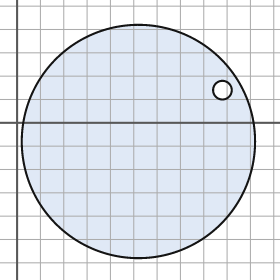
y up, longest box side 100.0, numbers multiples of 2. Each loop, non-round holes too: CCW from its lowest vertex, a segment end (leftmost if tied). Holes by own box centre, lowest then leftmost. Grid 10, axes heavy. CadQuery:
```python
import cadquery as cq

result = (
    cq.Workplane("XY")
    .moveTo(52.0, -8.0)
    .circle(50.0)
    .moveTo(88.0, 14.0)
    .circle(4.0)
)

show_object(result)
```